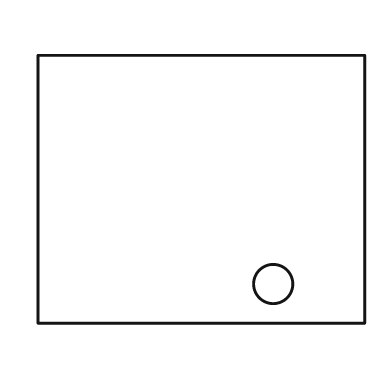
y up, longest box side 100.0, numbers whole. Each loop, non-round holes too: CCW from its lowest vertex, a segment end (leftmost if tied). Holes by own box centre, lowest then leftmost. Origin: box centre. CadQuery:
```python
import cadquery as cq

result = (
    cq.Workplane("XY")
    .moveTo(-50.0, -41.0)
    .lineTo(50.0, -41.0)
    .lineTo(50.0, 41.0)
    .lineTo(-50.0, 41.0)
    .close()
    .moveTo(22.0, -29.0)
    .circle(6.0)
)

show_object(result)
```